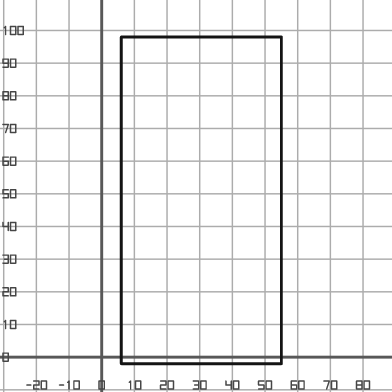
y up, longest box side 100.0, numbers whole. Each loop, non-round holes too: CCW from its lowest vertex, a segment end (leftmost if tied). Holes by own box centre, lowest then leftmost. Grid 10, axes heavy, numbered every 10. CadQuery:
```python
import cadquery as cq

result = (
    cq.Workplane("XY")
    .moveTo(6.0, -2.0)
    .lineTo(55.0, -2.0)
    .lineTo(55.0, 98.0)
    .lineTo(6.0, 98.0)
    .close()
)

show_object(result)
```